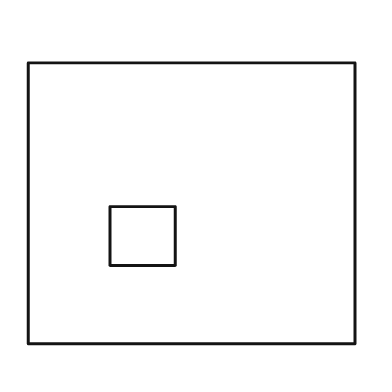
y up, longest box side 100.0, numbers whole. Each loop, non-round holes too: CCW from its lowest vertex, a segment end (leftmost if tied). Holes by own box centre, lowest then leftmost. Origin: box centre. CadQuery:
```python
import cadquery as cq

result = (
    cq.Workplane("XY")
    .moveTo(-50.0, -43.0)
    .lineTo(50.0, -43.0)
    .lineTo(50.0, 43.0)
    .lineTo(-50.0, 43.0)
    .close()
    .moveTo(-25.0, -19.0)
    .lineTo(-5.0, -19.0)
    .lineTo(-5.0, -1.0)
    .lineTo(-25.0, -1.0)
    .close()
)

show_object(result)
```